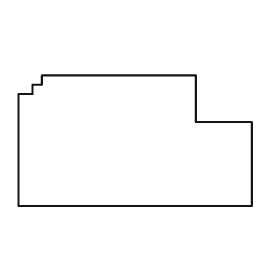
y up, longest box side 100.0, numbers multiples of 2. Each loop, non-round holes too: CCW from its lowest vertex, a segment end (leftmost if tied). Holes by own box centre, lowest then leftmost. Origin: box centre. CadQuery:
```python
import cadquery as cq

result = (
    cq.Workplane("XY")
    .moveTo(-50.0, -28.0)
    .lineTo(50.0, -28.0)
    .lineTo(50.0, 8.0)
    .lineTo(26.0, 8.0)
    .lineTo(26.0, 28.0)
    .lineTo(-40.0, 28.0)
    .lineTo(-40.0, 24.0)
    .lineTo(-44.0, 24.0)
    .lineTo(-44.0, 20.0)
    .lineTo(-50.0, 20.0)
    .close()
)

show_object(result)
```